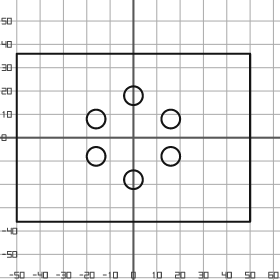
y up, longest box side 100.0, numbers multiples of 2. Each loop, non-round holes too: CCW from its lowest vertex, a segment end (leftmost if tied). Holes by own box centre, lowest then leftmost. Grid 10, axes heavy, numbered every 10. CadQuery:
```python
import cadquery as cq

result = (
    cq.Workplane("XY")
    .moveTo(-50.0, -36.0)
    .lineTo(50.0, -36.0)
    .lineTo(50.0, 36.0)
    .lineTo(-50.0, 36.0)
    .close()
    .moveTo(0.0, -18.0)
    .circle(4.0)
    .moveTo(-16.0, -8.0)
    .circle(4.0)
    .moveTo(16.0, -8.0)
    .circle(4.0)
    .moveTo(-16.0, 8.0)
    .circle(4.0)
    .moveTo(16.0, 8.0)
    .circle(4.0)
    .moveTo(0.0, 18.0)
    .circle(4.0)
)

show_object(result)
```